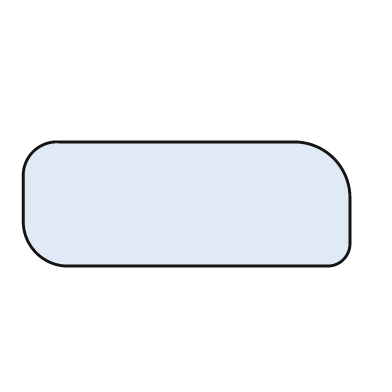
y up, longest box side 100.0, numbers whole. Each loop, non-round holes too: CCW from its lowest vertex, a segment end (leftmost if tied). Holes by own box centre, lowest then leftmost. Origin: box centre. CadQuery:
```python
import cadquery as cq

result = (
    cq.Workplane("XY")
    .moveTo(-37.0, -19.0)
    .lineTo(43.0, -19.0)
    .threePointArc((48.0, -17.0), (50.0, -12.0))
    .lineTo(50.0, 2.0)
    .threePointArc((45.0, 14.0), (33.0, 19.0))
    .lineTo(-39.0, 19.0)
    .threePointArc((-47.0, 16.0), (-50.0, 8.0))
    .lineTo(-50.0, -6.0)
    .threePointArc((-46.0, -15.0), (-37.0, -19.0))
    .close()
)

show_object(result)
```